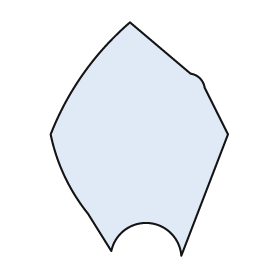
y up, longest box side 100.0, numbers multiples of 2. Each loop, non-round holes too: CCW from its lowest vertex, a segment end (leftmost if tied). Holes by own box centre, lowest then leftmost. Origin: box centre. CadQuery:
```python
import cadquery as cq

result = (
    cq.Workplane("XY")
    .moveTo(18.0, -50.0)
    .lineTo(38.0, 2.0)
    .lineTo(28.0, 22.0)
    .threePointArc((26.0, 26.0), (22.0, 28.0))
    .lineTo(-4.0, 50.0)
    .threePointArc((-24.0, 28.0), (-38.0, 2.0))
    .threePointArc((-32.0, -16.0), (-22.0, -32.0))
    .lineTo(-12.0, -48.0)
    .threePointArc((4.0, -36.0), (18.0, -50.0))
    .close()
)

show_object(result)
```